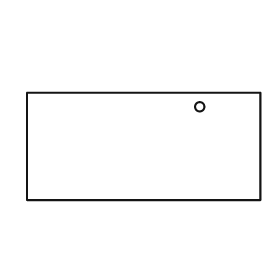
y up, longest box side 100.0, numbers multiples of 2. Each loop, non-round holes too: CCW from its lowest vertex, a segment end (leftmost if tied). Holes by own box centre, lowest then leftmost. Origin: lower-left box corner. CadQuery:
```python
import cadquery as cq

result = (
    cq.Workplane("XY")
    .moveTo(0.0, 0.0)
    .lineTo(100.0, 0.0)
    .lineTo(100.0, 46.0)
    .lineTo(0.0, 46.0)
    .close()
    .moveTo(74.0, 40.0)
    .circle(2.0)
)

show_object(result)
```